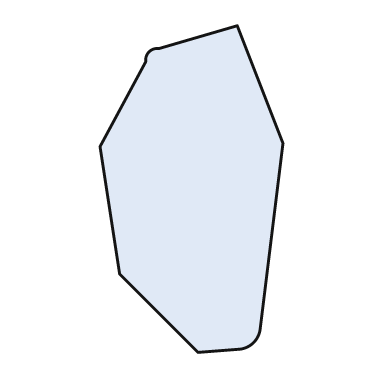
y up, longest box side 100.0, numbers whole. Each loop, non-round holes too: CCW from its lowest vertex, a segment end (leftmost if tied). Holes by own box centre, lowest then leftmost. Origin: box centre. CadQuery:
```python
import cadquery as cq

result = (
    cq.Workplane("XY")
    .moveTo(2.0, -50.0)
    .lineTo(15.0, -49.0)
    .threePointArc((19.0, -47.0), (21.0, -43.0))
    .lineTo(28.0, 14.0)
    .lineTo(14.0, 50.0)
    .lineTo(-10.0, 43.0)
    .threePointArc((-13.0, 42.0), (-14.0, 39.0))
    .lineTo(-28.0, 13.0)
    .lineTo(-22.0, -26.0)
    .close()
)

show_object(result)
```